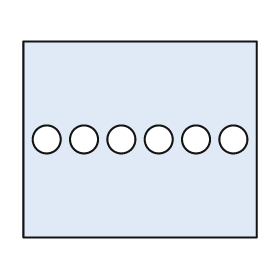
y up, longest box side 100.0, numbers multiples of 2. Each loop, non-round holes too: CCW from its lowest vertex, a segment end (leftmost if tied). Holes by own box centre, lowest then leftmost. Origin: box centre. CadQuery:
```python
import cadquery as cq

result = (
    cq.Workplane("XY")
    .moveTo(-50.0, -42.0)
    .lineTo(50.0, -42.0)
    .lineTo(50.0, 42.0)
    .lineTo(-50.0, 42.0)
    .close()
    .moveTo(-40.0, 0.0)
    .circle(6.0)
    .moveTo(-24.0, 0.0)
    .circle(6.0)
    .moveTo(-8.0, 0.0)
    .circle(6.0)
    .moveTo(8.0, 0.0)
    .circle(6.0)
    .moveTo(24.0, 0.0)
    .circle(6.0)
    .moveTo(40.0, 0.0)
    .circle(6.0)
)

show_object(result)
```